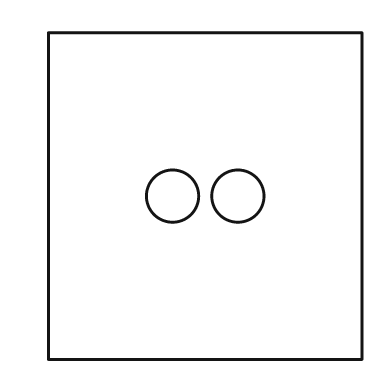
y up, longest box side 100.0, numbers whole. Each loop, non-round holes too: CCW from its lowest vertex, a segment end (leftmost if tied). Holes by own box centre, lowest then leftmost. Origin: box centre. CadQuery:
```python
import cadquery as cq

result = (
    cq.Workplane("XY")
    .moveTo(-48.0, -50.0)
    .lineTo(48.0, -50.0)
    .lineTo(48.0, 50.0)
    .lineTo(-48.0, 50.0)
    .close()
    .moveTo(-10.0, 0.0)
    .circle(8.0)
    .moveTo(10.0, 0.0)
    .circle(8.0)
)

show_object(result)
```